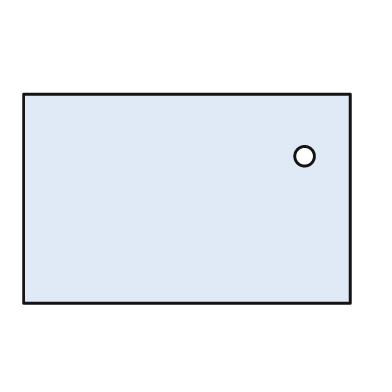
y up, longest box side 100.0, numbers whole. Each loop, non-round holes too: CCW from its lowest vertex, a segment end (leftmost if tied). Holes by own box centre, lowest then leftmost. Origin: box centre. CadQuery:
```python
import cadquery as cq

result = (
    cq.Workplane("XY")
    .moveTo(-50.0, -32.0)
    .lineTo(50.0, -32.0)
    .lineTo(50.0, 32.0)
    .lineTo(-50.0, 32.0)
    .close()
    .moveTo(36.0, 13.0)
    .circle(3.0)
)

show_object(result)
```